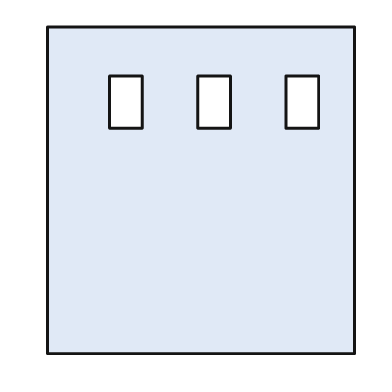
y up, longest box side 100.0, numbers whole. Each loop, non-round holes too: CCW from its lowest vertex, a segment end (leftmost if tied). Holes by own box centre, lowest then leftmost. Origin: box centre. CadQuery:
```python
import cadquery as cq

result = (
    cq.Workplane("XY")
    .moveTo(-47.0, -50.0)
    .lineTo(47.0, -50.0)
    .lineTo(47.0, 50.0)
    .lineTo(-47.0, 50.0)
    .close()
    .moveTo(-28.0, 19.0)
    .lineTo(-18.0, 19.0)
    .lineTo(-18.0, 35.0)
    .lineTo(-28.0, 35.0)
    .close()
    .moveTo(-1.0, 19.0)
    .lineTo(9.0, 19.0)
    .lineTo(9.0, 35.0)
    .lineTo(-1.0, 35.0)
    .close()
    .moveTo(26.0, 19.0)
    .lineTo(36.0, 19.0)
    .lineTo(36.0, 35.0)
    .lineTo(26.0, 35.0)
    .close()
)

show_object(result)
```